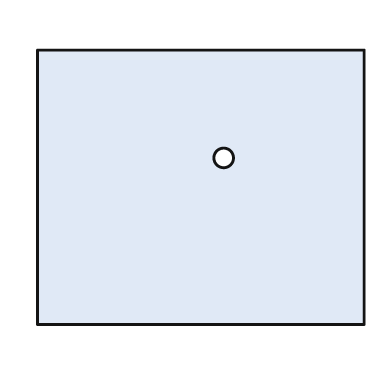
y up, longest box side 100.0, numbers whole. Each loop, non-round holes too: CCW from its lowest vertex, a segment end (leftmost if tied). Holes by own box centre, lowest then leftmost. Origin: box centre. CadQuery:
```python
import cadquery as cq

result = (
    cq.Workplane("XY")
    .moveTo(-50.0, -42.0)
    .lineTo(50.0, -42.0)
    .lineTo(50.0, 42.0)
    .lineTo(-50.0, 42.0)
    .close()
    .moveTo(7.0, 9.0)
    .circle(3.0)
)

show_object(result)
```